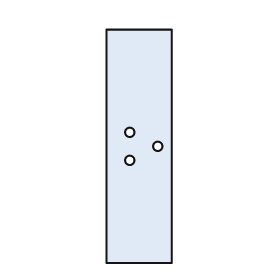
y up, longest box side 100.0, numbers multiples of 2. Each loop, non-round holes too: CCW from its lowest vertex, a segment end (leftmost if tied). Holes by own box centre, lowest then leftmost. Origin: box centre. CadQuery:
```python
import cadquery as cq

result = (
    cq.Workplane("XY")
    .moveTo(-14.0, -50.0)
    .lineTo(14.0, -50.0)
    .lineTo(14.0, 50.0)
    .lineTo(-14.0, 50.0)
    .close()
    .moveTo(-4.0, -6.0)
    .circle(2.0)
    .moveTo(8.0, 0.0)
    .circle(2.0)
    .moveTo(-4.0, 6.0)
    .circle(2.0)
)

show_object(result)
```